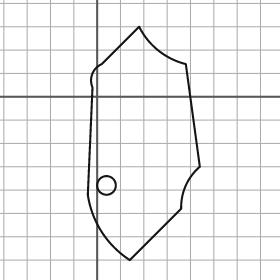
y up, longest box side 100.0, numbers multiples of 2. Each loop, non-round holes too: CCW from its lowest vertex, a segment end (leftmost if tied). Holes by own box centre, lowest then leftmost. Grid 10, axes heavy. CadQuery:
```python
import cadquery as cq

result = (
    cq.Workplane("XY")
    .moveTo(14.0, -70.0)
    .lineTo(36.0, -48.0)
    .threePointArc((38.0, -38.0), (44.0, -30.0))
    .lineTo(38.0, 14.0)
    .threePointArc((26.0, 20.0), (18.0, 30.0))
    .lineTo(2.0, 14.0)
    .threePointArc((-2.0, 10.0), (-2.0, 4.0))
    .lineTo(-4.0, -42.0)
    .threePointArc((2.0, -58.0), (14.0, -70.0))
    .close()
    .moveTo(4.0, -38.0)
    .circle(4.0)
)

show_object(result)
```